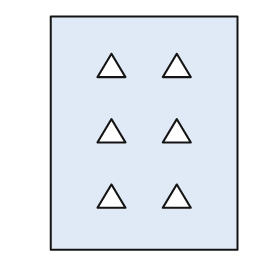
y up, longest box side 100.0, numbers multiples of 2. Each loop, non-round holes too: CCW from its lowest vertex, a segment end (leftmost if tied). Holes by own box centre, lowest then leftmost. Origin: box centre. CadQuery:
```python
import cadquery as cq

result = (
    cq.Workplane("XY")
    .moveTo(-40.0, -50.0)
    .lineTo(40.0, -50.0)
    .lineTo(40.0, 50.0)
    .lineTo(-40.0, 50.0)
    .close()
    .moveTo(-20.0, -32.0)
    .lineTo(-8.0, -32.0)
    .lineTo(-14.0, -22.0)
    .close()
    .moveTo(8.0, -32.0)
    .lineTo(20.0, -32.0)
    .lineTo(14.0, -22.0)
    .close()
    .moveTo(-20.0, -4.0)
    .lineTo(-8.0, -4.0)
    .lineTo(-14.0, 6.0)
    .close()
    .moveTo(8.0, -4.0)
    .lineTo(20.0, -4.0)
    .lineTo(14.0, 6.0)
    .close()
    .moveTo(-20.0, 24.0)
    .lineTo(-8.0, 24.0)
    .lineTo(-14.0, 34.0)
    .close()
    .moveTo(8.0, 24.0)
    .lineTo(20.0, 24.0)
    .lineTo(14.0, 34.0)
    .close()
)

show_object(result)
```